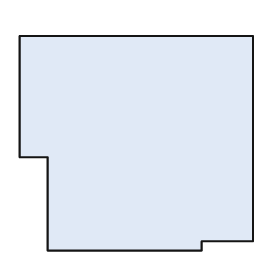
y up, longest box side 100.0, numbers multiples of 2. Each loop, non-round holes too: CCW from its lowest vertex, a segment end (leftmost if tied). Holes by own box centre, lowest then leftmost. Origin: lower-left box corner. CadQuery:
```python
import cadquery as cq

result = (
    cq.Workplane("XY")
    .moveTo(12.0, 0.0)
    .lineTo(78.0, 0.0)
    .lineTo(78.0, 4.0)
    .lineTo(100.0, 4.0)
    .lineTo(100.0, 92.0)
    .lineTo(0.0, 92.0)
    .lineTo(0.0, 40.0)
    .lineTo(12.0, 40.0)
    .close()
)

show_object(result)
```